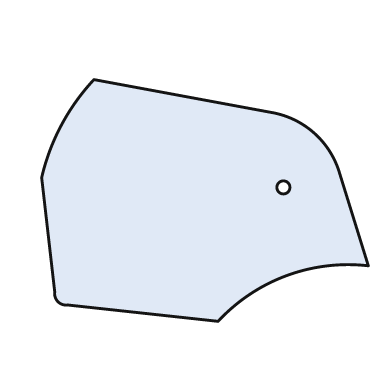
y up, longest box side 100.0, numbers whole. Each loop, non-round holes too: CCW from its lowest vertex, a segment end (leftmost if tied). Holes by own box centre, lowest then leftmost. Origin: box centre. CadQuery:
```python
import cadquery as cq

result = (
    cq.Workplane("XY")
    .moveTo(4.0, -37.0)
    .threePointArc((25.0, -23.0), (50.0, -20.0))
    .lineTo(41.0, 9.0)
    .threePointArc((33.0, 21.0), (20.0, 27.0))
    .lineTo(-34.0, 37.0)
    .threePointArc((-44.0, 23.0), (-50.0, 7.0))
    .lineTo(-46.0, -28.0)
    .threePointArc((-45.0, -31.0), (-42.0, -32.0))
    .close()
    .moveTo(24.0, 4.0)
    .circle(2.0)
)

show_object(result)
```